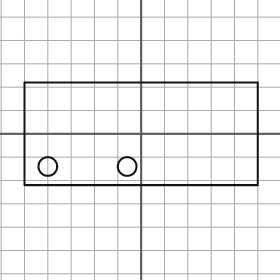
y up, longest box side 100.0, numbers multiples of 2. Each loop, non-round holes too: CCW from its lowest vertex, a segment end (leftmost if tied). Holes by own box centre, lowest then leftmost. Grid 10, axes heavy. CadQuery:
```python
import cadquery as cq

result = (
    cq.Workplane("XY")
    .moveTo(-50.0, -22.0)
    .lineTo(50.0, -22.0)
    .lineTo(50.0, 22.0)
    .lineTo(-50.0, 22.0)
    .close()
    .moveTo(-40.0, -14.0)
    .circle(4.0)
    .moveTo(-6.0, -14.0)
    .circle(4.0)
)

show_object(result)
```